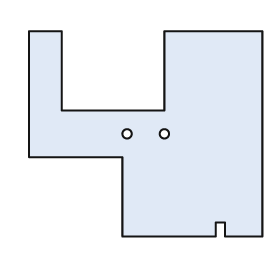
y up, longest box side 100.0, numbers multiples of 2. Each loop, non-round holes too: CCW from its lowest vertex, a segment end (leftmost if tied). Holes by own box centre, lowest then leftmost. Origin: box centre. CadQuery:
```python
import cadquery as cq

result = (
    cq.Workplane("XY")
    .moveTo(-10.0, -44.0)
    .lineTo(30.0, -44.0)
    .lineTo(30.0, -38.0)
    .lineTo(34.0, -38.0)
    .lineTo(34.0, -44.0)
    .lineTo(50.0, -44.0)
    .lineTo(50.0, 44.0)
    .lineTo(8.0, 44.0)
    .lineTo(8.0, 10.0)
    .lineTo(-36.0, 10.0)
    .lineTo(-36.0, 44.0)
    .lineTo(-50.0, 44.0)
    .lineTo(-50.0, -10.0)
    .lineTo(-10.0, -10.0)
    .close()
    .moveTo(-8.0, 0.0)
    .circle(2.0)
    .moveTo(8.0, 0.0)
    .circle(2.0)
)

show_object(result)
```